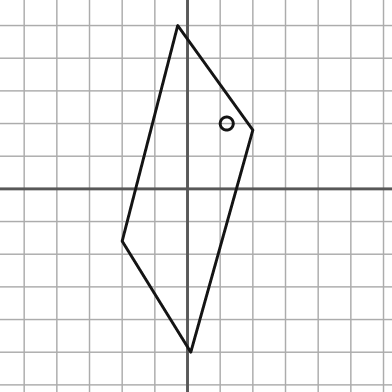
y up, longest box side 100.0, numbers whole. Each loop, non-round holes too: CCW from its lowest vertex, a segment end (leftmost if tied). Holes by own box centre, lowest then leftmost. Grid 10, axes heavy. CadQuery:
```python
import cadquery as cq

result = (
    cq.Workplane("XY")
    .moveTo(1.0, -50.0)
    .lineTo(20.0, 18.0)
    .lineTo(-3.0, 50.0)
    .lineTo(-20.0, -16.0)
    .close()
    .moveTo(12.0, 20.0)
    .circle(2.0)
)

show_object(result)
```